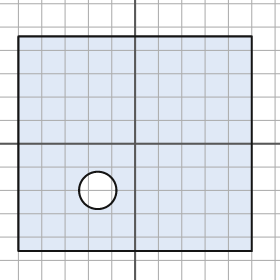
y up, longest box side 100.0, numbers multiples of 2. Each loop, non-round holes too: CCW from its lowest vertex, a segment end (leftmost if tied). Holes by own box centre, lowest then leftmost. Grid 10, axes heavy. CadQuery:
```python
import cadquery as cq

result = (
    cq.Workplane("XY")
    .moveTo(-50.0, -46.0)
    .lineTo(50.0, -46.0)
    .lineTo(50.0, 46.0)
    .lineTo(-50.0, 46.0)
    .close()
    .moveTo(-16.0, -20.0)
    .circle(8.0)
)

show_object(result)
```